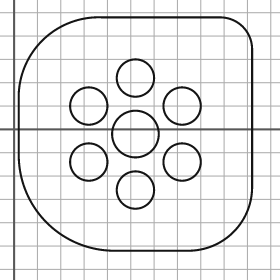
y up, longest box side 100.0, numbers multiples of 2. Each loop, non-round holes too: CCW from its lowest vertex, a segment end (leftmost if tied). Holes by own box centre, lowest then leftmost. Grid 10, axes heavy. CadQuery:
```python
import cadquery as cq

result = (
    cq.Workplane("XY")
    .moveTo(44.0, -52.0)
    .lineTo(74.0, -52.0)
    .threePointArc((94.0, -44.0), (102.0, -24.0))
    .lineTo(102.0, 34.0)
    .threePointArc((98.0, 44.0), (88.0, 48.0))
    .lineTo(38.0, 48.0)
    .threePointArc((12.0, 38.0), (2.0, 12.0))
    .lineTo(2.0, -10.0)
    .threePointArc((14.0, -40.0), (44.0, -52.0))
    .close()
    .moveTo(52.0, -26.0)
    .circle(8.0)
    .moveTo(32.0, -14.0)
    .circle(8.0)
    .moveTo(72.0, -14.0)
    .circle(8.0)
    .moveTo(52.0, -2.0)
    .circle(10.0)
    .moveTo(32.0, 10.0)
    .circle(8.0)
    .moveTo(72.0, 10.0)
    .circle(8.0)
    .moveTo(52.0, 22.0)
    .circle(8.0)
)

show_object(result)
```